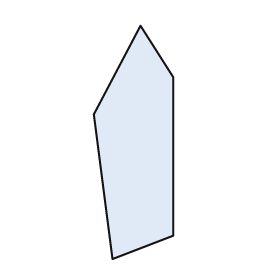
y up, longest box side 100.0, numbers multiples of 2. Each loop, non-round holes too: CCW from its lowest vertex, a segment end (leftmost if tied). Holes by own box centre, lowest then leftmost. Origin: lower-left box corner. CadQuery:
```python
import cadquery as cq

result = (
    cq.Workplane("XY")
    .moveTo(8.0, 0.0)
    .lineTo(34.0, 10.0)
    .lineTo(34.0, 78.0)
    .lineTo(20.0, 100.0)
    .lineTo(0.0, 62.0)
    .close()
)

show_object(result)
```